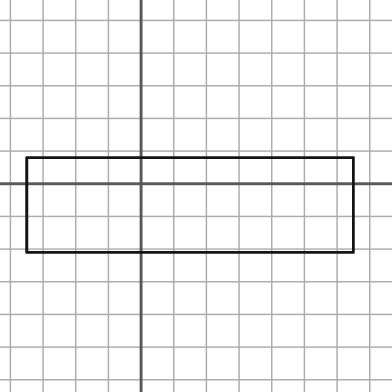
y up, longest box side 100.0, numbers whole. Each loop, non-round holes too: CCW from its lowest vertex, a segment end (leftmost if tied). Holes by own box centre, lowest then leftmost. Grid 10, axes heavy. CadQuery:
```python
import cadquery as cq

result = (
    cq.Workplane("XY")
    .moveTo(-35.0, -21.0)
    .lineTo(65.0, -21.0)
    .lineTo(65.0, 8.0)
    .lineTo(-35.0, 8.0)
    .close()
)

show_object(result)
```